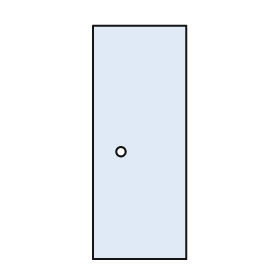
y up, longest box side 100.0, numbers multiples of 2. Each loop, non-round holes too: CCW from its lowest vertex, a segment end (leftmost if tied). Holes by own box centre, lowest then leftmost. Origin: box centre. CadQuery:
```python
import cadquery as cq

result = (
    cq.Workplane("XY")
    .moveTo(-20.0, -50.0)
    .lineTo(20.0, -50.0)
    .lineTo(20.0, 50.0)
    .lineTo(-20.0, 50.0)
    .close()
    .moveTo(-8.0, -4.0)
    .circle(2.0)
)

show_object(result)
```